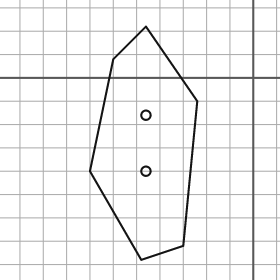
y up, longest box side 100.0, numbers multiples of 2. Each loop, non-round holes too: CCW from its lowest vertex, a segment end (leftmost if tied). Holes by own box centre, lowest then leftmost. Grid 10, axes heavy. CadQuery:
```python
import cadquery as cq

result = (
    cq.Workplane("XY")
    .moveTo(-48.0, -78.0)
    .lineTo(-30.0, -72.0)
    .lineTo(-24.0, -10.0)
    .lineTo(-46.0, 22.0)
    .lineTo(-60.0, 8.0)
    .lineTo(-70.0, -40.0)
    .close()
    .moveTo(-46.0, -40.0)
    .circle(2.0)
    .moveTo(-46.0, -16.0)
    .circle(2.0)
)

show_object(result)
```